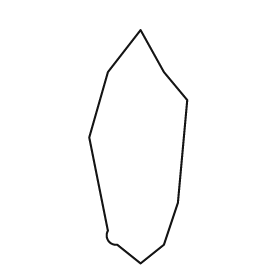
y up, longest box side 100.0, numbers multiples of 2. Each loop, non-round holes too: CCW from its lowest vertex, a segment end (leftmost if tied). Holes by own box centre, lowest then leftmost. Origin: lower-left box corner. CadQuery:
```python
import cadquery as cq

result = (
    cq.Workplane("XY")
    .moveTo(22.0, 0.0)
    .lineTo(32.0, 8.0)
    .lineTo(38.0, 26.0)
    .lineTo(42.0, 70.0)
    .lineTo(32.0, 82.0)
    .lineTo(22.0, 100.0)
    .lineTo(8.0, 82.0)
    .lineTo(0.0, 54.0)
    .lineTo(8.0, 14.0)
    .threePointArc((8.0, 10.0), (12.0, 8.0))
    .close()
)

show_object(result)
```